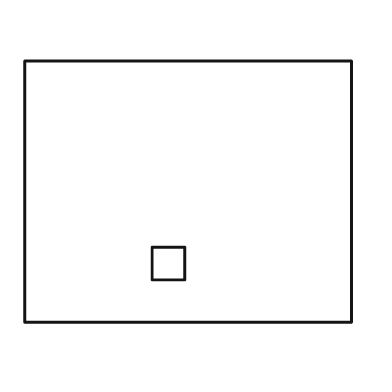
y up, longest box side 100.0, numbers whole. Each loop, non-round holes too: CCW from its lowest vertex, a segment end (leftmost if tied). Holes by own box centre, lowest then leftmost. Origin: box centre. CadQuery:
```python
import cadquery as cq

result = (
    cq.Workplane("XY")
    .moveTo(-50.0, -40.0)
    .lineTo(50.0, -40.0)
    .lineTo(50.0, 40.0)
    .lineTo(-50.0, 40.0)
    .close()
    .moveTo(-11.0, -27.0)
    .lineTo(-1.0, -27.0)
    .lineTo(-1.0, -17.0)
    .lineTo(-11.0, -17.0)
    .close()
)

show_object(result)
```